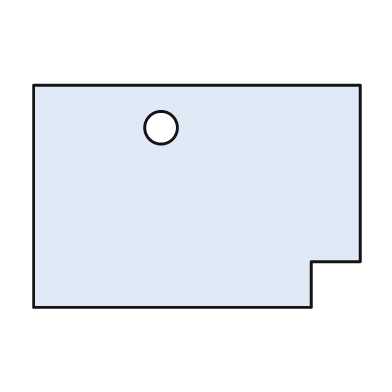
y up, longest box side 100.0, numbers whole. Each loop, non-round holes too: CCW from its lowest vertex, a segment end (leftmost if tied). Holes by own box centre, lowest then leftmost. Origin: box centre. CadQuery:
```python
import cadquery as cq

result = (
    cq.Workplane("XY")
    .moveTo(-50.0, -34.0)
    .lineTo(35.0, -34.0)
    .lineTo(35.0, -20.0)
    .lineTo(50.0, -20.0)
    .lineTo(50.0, 34.0)
    .lineTo(-50.0, 34.0)
    .close()
    .moveTo(-11.0, 21.0)
    .circle(5.0)
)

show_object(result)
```